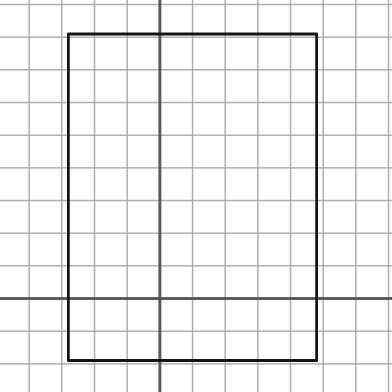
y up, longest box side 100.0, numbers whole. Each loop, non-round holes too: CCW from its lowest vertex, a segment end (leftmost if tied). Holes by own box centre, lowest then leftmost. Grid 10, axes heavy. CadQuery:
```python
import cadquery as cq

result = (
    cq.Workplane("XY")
    .moveTo(-28.0, -19.0)
    .lineTo(48.0, -19.0)
    .lineTo(48.0, 81.0)
    .lineTo(-28.0, 81.0)
    .close()
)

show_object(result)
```